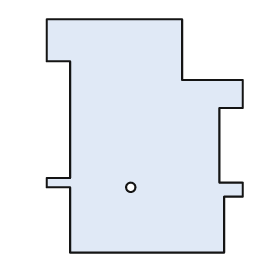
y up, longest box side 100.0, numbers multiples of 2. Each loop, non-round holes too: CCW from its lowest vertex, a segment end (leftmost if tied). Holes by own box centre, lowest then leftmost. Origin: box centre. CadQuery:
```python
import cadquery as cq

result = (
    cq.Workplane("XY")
    .moveTo(-32.0, -50.0)
    .lineTo(34.0, -50.0)
    .lineTo(34.0, -26.0)
    .lineTo(42.0, -26.0)
    .lineTo(42.0, -20.0)
    .lineTo(32.0, -20.0)
    .lineTo(32.0, 12.0)
    .lineTo(42.0, 12.0)
    .lineTo(42.0, 24.0)
    .lineTo(16.0, 24.0)
    .lineTo(16.0, 50.0)
    .lineTo(-42.0, 50.0)
    .lineTo(-42.0, 32.0)
    .lineTo(-32.0, 32.0)
    .lineTo(-32.0, -18.0)
    .lineTo(-42.0, -18.0)
    .lineTo(-42.0, -22.0)
    .lineTo(-32.0, -22.0)
    .close()
    .moveTo(-6.0, -22.0)
    .circle(2.0)
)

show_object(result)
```